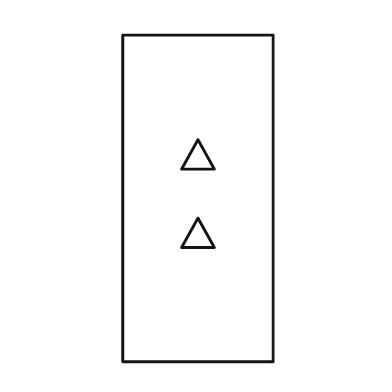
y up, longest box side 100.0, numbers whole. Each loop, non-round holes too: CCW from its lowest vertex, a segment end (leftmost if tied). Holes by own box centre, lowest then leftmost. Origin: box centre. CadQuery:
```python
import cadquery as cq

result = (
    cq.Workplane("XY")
    .moveTo(-23.0, -50.0)
    .lineTo(23.0, -50.0)
    .lineTo(23.0, 50.0)
    .lineTo(-23.0, 50.0)
    .close()
    .moveTo(-5.0, -15.0)
    .lineTo(5.0, -15.0)
    .lineTo(0.0, -6.0)
    .close()
    .moveTo(-5.0, 9.0)
    .lineTo(5.0, 9.0)
    .lineTo(0.0, 18.0)
    .close()
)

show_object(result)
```